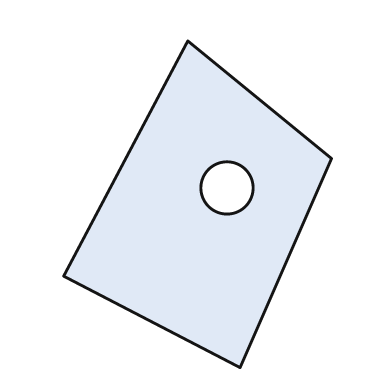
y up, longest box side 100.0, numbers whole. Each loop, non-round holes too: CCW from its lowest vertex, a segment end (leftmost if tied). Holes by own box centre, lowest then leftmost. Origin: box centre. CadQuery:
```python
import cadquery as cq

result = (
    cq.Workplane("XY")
    .moveTo(13.0, -50.0)
    .lineTo(41.0, 14.0)
    .lineTo(-3.0, 50.0)
    .lineTo(-41.0, -22.0)
    .close()
    .moveTo(9.0, 5.0)
    .circle(8.0)
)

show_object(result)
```